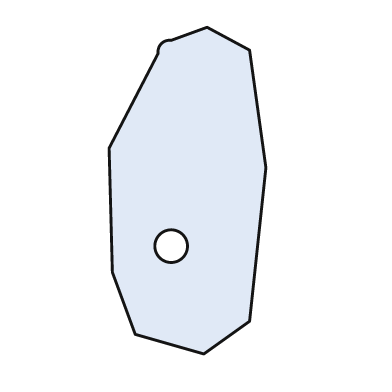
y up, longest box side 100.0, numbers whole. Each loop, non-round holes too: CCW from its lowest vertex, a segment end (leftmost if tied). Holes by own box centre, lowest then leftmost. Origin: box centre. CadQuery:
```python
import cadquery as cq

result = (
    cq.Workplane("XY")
    .moveTo(5.0, -50.0)
    .lineTo(19.0, -40.0)
    .lineTo(24.0, 7.0)
    .lineTo(19.0, 43.0)
    .lineTo(6.0, 50.0)
    .lineTo(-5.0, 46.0)
    .threePointArc((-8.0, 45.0), (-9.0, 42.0))
    .lineTo(-24.0, 13.0)
    .lineTo(-23.0, -25.0)
    .lineTo(-16.0, -44.0)
    .close()
    .moveTo(-5.0, -17.0)
    .circle(5.0)
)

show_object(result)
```